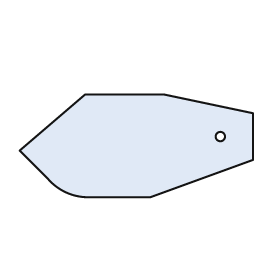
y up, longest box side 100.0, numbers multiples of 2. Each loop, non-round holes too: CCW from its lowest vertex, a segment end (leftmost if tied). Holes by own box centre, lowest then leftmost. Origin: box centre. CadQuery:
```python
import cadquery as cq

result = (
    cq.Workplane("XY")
    .moveTo(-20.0, -22.0)
    .lineTo(6.0, -22.0)
    .lineTo(50.0, -6.0)
    .lineTo(50.0, 14.0)
    .lineTo(12.0, 22.0)
    .lineTo(-22.0, 22.0)
    .lineTo(-50.0, -2.0)
    .lineTo(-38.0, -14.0)
    .threePointArc((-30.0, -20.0), (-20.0, -22.0))
    .close()
    .moveTo(36.0, 4.0)
    .circle(2.0)
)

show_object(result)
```